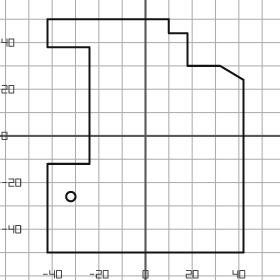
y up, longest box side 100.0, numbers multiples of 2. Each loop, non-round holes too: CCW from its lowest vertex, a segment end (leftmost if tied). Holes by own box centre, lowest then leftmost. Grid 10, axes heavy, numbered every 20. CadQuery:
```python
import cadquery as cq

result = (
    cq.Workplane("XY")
    .moveTo(-42.0, -50.0)
    .lineTo(42.0, -50.0)
    .lineTo(42.0, 24.0)
    .lineTo(32.0, 30.0)
    .lineTo(18.0, 30.0)
    .lineTo(18.0, 44.0)
    .lineTo(10.0, 44.0)
    .lineTo(10.0, 50.0)
    .lineTo(-42.0, 50.0)
    .lineTo(-42.0, 38.0)
    .lineTo(-24.0, 38.0)
    .lineTo(-24.0, -12.0)
    .lineTo(-42.0, -12.0)
    .close()
    .moveTo(-32.0, -26.0)
    .circle(2.0)
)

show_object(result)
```